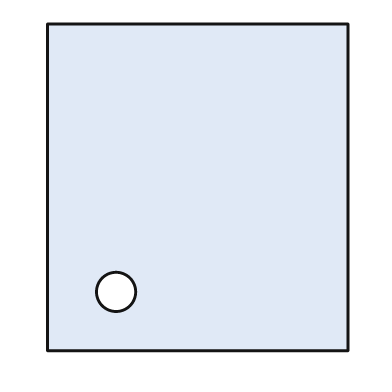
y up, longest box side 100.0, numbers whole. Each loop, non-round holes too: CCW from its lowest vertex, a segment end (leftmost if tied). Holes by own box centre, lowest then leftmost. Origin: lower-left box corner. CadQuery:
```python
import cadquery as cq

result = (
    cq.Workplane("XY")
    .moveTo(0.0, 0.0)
    .lineTo(92.0, 0.0)
    .lineTo(92.0, 100.0)
    .lineTo(0.0, 100.0)
    .close()
    .moveTo(21.0, 18.0)
    .circle(6.0)
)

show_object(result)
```